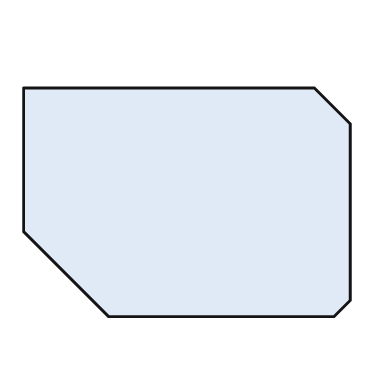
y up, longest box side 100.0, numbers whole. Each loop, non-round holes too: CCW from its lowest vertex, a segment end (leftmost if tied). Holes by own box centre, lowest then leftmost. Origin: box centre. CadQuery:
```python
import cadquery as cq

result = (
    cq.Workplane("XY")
    .moveTo(-24.0, -35.0)
    .lineTo(45.0, -35.0)
    .lineTo(50.0, -30.0)
    .lineTo(50.0, 24.0)
    .lineTo(39.0, 35.0)
    .lineTo(-50.0, 35.0)
    .lineTo(-50.0, -9.0)
    .close()
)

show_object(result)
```